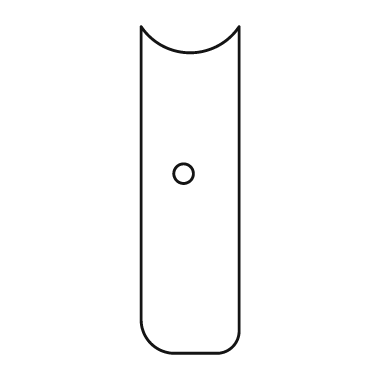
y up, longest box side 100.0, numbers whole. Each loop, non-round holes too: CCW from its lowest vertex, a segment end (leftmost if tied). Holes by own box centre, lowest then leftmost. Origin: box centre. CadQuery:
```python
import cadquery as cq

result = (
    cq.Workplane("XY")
    .moveTo(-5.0, -50.0)
    .lineTo(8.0, -50.0)
    .threePointArc((13.0, -48.0), (15.0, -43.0))
    .lineTo(15.0, 50.0)
    .threePointArc((0.0, 42.0), (-15.0, 50.0))
    .lineTo(-15.0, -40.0)
    .threePointArc((-12.0, -47.0), (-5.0, -50.0))
    .close()
    .moveTo(-2.0, 5.0)
    .circle(3.0)
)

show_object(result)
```